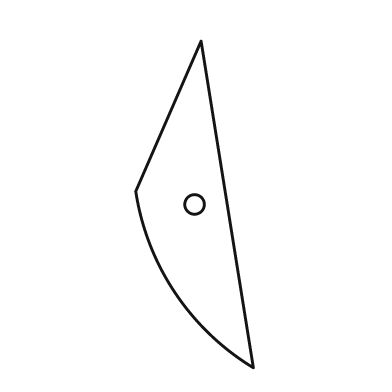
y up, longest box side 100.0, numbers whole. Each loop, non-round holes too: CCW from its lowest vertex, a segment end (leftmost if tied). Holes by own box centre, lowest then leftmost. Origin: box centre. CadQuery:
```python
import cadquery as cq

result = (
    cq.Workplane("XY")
    .moveTo(18.0, -50.0)
    .lineTo(2.0, 50.0)
    .lineTo(-18.0, 4.0)
    .threePointArc((-6.0, -27.0), (18.0, -50.0))
    .close()
    .moveTo(0.0, 0.0)
    .circle(3.0)
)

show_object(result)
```